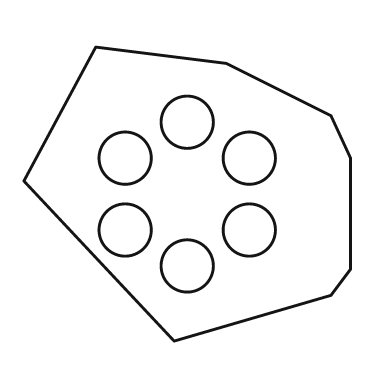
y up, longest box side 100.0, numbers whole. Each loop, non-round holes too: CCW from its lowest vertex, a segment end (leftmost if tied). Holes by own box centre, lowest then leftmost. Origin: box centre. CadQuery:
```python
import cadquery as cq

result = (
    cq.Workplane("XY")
    .moveTo(-4.0, -45.0)
    .lineTo(44.0, -31.0)
    .lineTo(50.0, -23.0)
    .lineTo(50.0, 11.0)
    .lineTo(44.0, 24.0)
    .lineTo(12.0, 40.0)
    .lineTo(-28.0, 45.0)
    .lineTo(-50.0, 4.0)
    .close()
    .moveTo(0.0, -22.0)
    .circle(8.0)
    .moveTo(-19.0, -11.0)
    .circle(8.0)
    .moveTo(19.0, -11.0)
    .circle(8.0)
    .moveTo(-19.0, 11.0)
    .circle(8.0)
    .moveTo(19.0, 11.0)
    .circle(8.0)
    .moveTo(0.0, 22.0)
    .circle(8.0)
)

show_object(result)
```